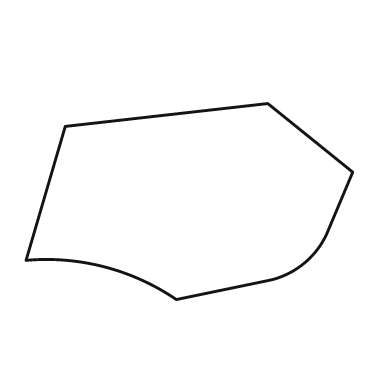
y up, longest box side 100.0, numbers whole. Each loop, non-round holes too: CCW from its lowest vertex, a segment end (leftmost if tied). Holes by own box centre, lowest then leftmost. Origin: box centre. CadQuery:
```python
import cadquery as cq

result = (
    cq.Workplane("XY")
    .moveTo(-4.0, -30.0)
    .lineTo(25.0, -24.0)
    .threePointArc((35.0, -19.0), (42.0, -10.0))
    .lineTo(50.0, 9.0)
    .lineTo(24.0, 30.0)
    .lineTo(-38.0, 23.0)
    .lineTo(-50.0, -18.0)
    .threePointArc((-26.0, -20.0), (-4.0, -30.0))
    .close()
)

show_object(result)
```